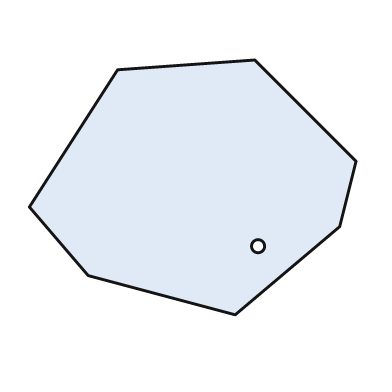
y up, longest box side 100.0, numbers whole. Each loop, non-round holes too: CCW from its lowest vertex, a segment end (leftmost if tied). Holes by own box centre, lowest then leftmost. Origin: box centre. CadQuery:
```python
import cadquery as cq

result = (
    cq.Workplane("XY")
    .moveTo(13.0, -39.0)
    .lineTo(45.0, -12.0)
    .lineTo(50.0, 8.0)
    .lineTo(19.0, 39.0)
    .lineTo(-23.0, 36.0)
    .lineTo(-50.0, -6.0)
    .lineTo(-32.0, -27.0)
    .close()
    .moveTo(20.0, -18.0)
    .circle(2.0)
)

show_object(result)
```